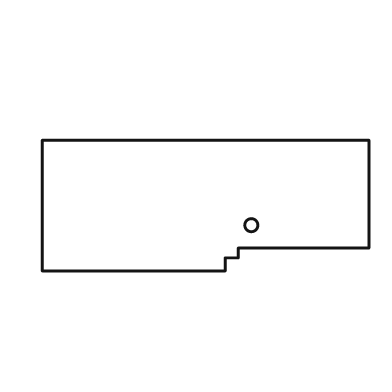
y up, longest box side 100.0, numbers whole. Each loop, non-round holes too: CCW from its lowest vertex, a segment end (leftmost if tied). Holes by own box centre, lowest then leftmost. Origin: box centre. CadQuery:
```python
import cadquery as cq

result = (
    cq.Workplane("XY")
    .moveTo(-50.0, -20.0)
    .lineTo(6.0, -20.0)
    .lineTo(6.0, -16.0)
    .lineTo(10.0, -16.0)
    .lineTo(10.0, -13.0)
    .lineTo(50.0, -13.0)
    .lineTo(50.0, 20.0)
    .lineTo(-50.0, 20.0)
    .close()
    .moveTo(14.0, -6.0)
    .circle(2.0)
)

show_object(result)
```